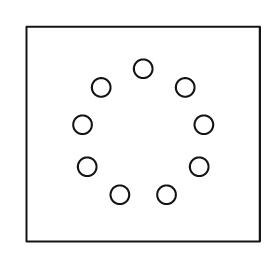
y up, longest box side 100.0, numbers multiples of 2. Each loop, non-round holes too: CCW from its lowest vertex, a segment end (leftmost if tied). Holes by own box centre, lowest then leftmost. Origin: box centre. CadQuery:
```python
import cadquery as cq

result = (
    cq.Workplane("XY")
    .moveTo(-50.0, -46.0)
    .lineTo(50.0, -46.0)
    .lineTo(50.0, 46.0)
    .lineTo(-50.0, 46.0)
    .close()
    .moveTo(-10.0, -26.0)
    .circle(4.0)
    .moveTo(10.0, -26.0)
    .circle(4.0)
    .moveTo(-24.0, -14.0)
    .circle(4.0)
    .moveTo(24.0, -14.0)
    .circle(4.0)
    .moveTo(-26.0, 4.0)
    .circle(4.0)
    .moveTo(26.0, 4.0)
    .circle(4.0)
    .moveTo(-18.0, 20.0)
    .circle(4.0)
    .moveTo(18.0, 20.0)
    .circle(4.0)
    .moveTo(0.0, 28.0)
    .circle(4.0)
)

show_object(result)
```